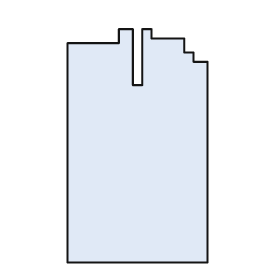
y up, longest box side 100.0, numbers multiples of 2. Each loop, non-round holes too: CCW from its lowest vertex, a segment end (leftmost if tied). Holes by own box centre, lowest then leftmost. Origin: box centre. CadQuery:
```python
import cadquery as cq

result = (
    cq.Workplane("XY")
    .moveTo(-30.0, -50.0)
    .lineTo(30.0, -50.0)
    .lineTo(30.0, 36.0)
    .lineTo(24.0, 36.0)
    .lineTo(24.0, 40.0)
    .lineTo(20.0, 40.0)
    .lineTo(20.0, 46.0)
    .lineTo(6.0, 46.0)
    .lineTo(6.0, 50.0)
    .lineTo(2.0, 50.0)
    .lineTo(2.0, 26.0)
    .lineTo(-2.0, 26.0)
    .lineTo(-2.0, 50.0)
    .lineTo(-8.0, 50.0)
    .lineTo(-8.0, 44.0)
    .lineTo(-30.0, 44.0)
    .close()
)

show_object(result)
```